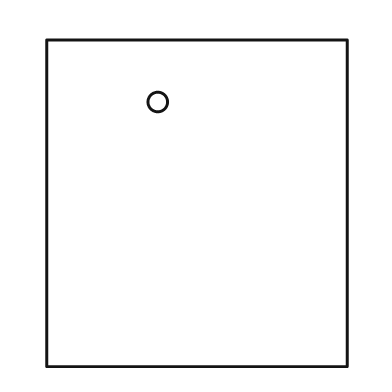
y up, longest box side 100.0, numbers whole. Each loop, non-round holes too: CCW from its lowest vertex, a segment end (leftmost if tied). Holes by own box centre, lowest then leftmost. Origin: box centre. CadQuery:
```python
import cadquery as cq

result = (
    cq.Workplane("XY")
    .moveTo(-46.0, -50.0)
    .lineTo(46.0, -50.0)
    .lineTo(46.0, 50.0)
    .lineTo(-46.0, 50.0)
    .close()
    .moveTo(-12.0, 31.0)
    .circle(3.0)
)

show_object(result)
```